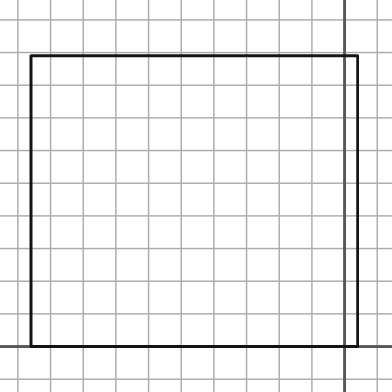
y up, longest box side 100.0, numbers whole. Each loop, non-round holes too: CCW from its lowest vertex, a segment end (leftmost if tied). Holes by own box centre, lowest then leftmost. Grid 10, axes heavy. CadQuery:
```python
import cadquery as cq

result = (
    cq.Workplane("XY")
    .moveTo(-96.0, 0.0)
    .lineTo(4.0, 0.0)
    .lineTo(4.0, 89.0)
    .lineTo(-96.0, 89.0)
    .close()
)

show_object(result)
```